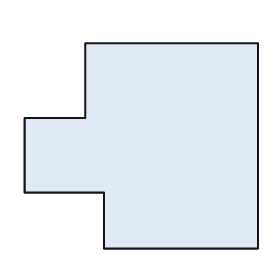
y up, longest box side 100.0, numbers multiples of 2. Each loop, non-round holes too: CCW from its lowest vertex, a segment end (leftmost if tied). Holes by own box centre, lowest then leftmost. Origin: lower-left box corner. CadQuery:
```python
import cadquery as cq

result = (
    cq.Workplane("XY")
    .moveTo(34.0, 0.0)
    .lineTo(100.0, 0.0)
    .lineTo(100.0, 88.0)
    .lineTo(26.0, 88.0)
    .lineTo(26.0, 56.0)
    .lineTo(0.0, 56.0)
    .lineTo(0.0, 24.0)
    .lineTo(34.0, 24.0)
    .close()
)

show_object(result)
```